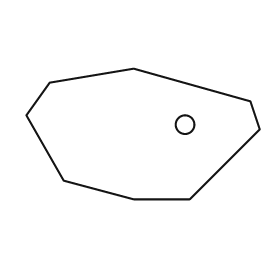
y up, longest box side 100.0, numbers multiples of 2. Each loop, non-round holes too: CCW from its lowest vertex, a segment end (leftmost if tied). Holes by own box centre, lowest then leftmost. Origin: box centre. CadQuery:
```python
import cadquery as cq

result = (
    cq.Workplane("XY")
    .moveTo(-4.0, -28.0)
    .lineTo(20.0, -28.0)
    .lineTo(50.0, 2.0)
    .lineTo(46.0, 14.0)
    .lineTo(-4.0, 28.0)
    .lineTo(-40.0, 22.0)
    .lineTo(-50.0, 8.0)
    .lineTo(-34.0, -20.0)
    .close()
    .moveTo(18.0, 4.0)
    .circle(4.0)
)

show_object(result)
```